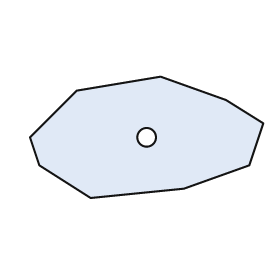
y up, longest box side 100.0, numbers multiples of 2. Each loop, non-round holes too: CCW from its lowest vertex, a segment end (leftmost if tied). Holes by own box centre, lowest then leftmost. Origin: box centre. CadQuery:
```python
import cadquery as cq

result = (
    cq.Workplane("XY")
    .moveTo(-24.0, -26.0)
    .lineTo(16.0, -22.0)
    .lineTo(44.0, -12.0)
    .lineTo(50.0, 6.0)
    .lineTo(34.0, 16.0)
    .lineTo(6.0, 26.0)
    .lineTo(-30.0, 20.0)
    .lineTo(-50.0, 0.0)
    .lineTo(-46.0, -12.0)
    .close()
    .moveTo(0.0, 0.0)
    .circle(4.0)
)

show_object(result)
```